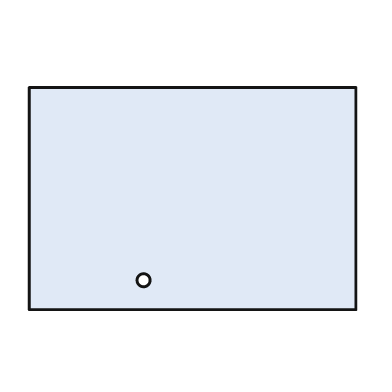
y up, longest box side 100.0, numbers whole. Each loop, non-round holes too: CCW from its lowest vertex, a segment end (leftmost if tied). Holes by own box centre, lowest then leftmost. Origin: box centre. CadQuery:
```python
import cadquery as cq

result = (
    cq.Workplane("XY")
    .moveTo(-50.0, -34.0)
    .lineTo(50.0, -34.0)
    .lineTo(50.0, 34.0)
    .lineTo(-50.0, 34.0)
    .close()
    .moveTo(-15.0, -25.0)
    .circle(2.0)
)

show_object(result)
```